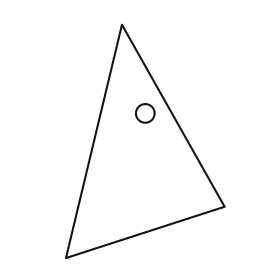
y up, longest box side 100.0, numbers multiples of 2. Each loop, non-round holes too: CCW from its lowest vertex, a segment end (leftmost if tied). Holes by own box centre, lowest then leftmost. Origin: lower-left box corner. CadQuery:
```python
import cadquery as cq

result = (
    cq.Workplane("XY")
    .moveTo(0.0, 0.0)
    .lineTo(68.0, 22.0)
    .lineTo(24.0, 100.0)
    .close()
    .moveTo(34.0, 62.0)
    .circle(4.0)
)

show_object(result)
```